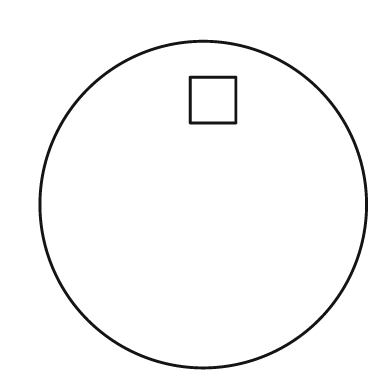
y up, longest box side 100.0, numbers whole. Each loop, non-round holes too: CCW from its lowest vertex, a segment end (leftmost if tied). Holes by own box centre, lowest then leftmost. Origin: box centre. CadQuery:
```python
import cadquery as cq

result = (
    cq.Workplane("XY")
    .moveTo(0.0, 0.0)
    .circle(50.0)
    .moveTo(-4.0, 25.0)
    .lineTo(10.0, 25.0)
    .lineTo(10.0, 39.0)
    .lineTo(-4.0, 39.0)
    .close()
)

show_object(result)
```